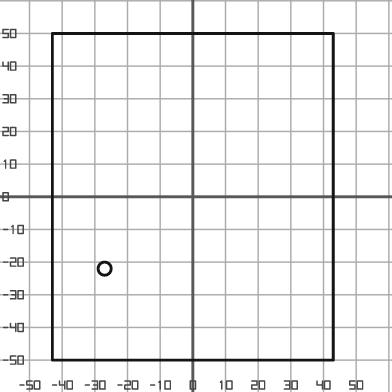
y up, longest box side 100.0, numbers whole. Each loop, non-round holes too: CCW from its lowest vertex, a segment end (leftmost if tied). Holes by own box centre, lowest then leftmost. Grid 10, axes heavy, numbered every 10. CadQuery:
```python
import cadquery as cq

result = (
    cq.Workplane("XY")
    .moveTo(-43.0, -50.0)
    .lineTo(43.0, -50.0)
    .lineTo(43.0, 50.0)
    .lineTo(-43.0, 50.0)
    .close()
    .moveTo(-27.0, -22.0)
    .circle(2.0)
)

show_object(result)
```